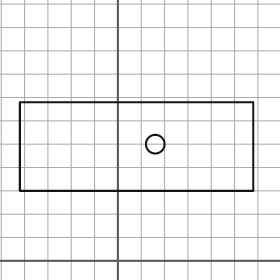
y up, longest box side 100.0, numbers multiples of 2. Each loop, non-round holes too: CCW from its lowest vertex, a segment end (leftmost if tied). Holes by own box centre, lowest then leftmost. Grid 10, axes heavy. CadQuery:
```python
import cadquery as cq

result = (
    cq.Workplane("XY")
    .moveTo(-42.0, 30.0)
    .lineTo(58.0, 30.0)
    .lineTo(58.0, 68.0)
    .lineTo(-42.0, 68.0)
    .close()
    .moveTo(16.0, 50.0)
    .circle(4.0)
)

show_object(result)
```